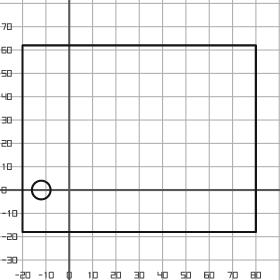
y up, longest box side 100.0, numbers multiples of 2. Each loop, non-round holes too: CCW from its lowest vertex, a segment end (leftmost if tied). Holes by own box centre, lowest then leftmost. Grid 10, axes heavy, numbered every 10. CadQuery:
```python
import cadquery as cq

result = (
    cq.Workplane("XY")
    .moveTo(-20.0, -18.0)
    .lineTo(80.0, -18.0)
    .lineTo(80.0, 62.0)
    .lineTo(-20.0, 62.0)
    .close()
    .moveTo(-12.0, 0.0)
    .circle(4.0)
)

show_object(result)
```